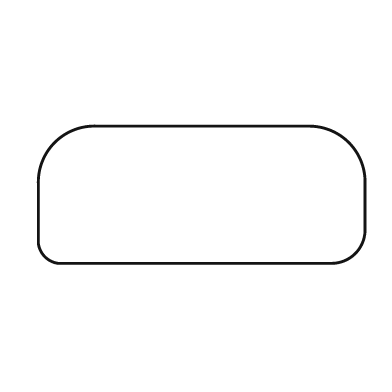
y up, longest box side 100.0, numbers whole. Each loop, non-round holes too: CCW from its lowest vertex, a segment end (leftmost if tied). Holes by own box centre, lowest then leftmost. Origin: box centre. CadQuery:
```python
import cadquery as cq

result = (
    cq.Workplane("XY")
    .moveTo(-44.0, -21.0)
    .lineTo(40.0, -21.0)
    .threePointArc((47.0, -18.0), (50.0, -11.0))
    .lineTo(50.0, 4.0)
    .threePointArc((45.0, 16.0), (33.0, 21.0))
    .lineTo(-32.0, 21.0)
    .threePointArc((-45.0, 16.0), (-50.0, 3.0))
    .lineTo(-50.0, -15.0)
    .threePointArc((-48.0, -19.0), (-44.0, -21.0))
    .close()
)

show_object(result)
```